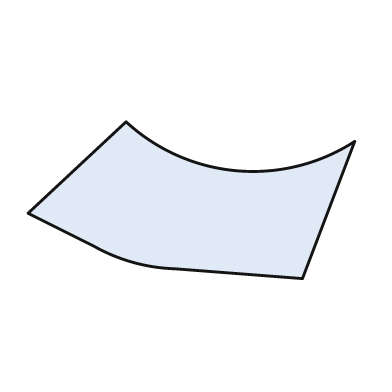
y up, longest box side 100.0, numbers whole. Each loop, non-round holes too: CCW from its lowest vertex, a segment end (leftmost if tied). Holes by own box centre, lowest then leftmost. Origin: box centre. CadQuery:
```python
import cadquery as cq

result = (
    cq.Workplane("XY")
    .moveTo(34.0, -24.0)
    .lineTo(50.0, 18.0)
    .threePointArc((14.0, 9.0), (-20.0, 24.0))
    .lineTo(-50.0, -4.0)
    .lineTo(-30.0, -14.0)
    .threePointArc((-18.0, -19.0), (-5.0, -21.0))
    .close()
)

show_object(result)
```